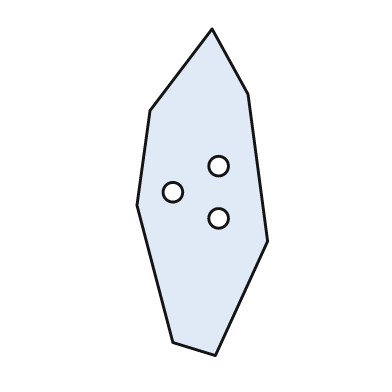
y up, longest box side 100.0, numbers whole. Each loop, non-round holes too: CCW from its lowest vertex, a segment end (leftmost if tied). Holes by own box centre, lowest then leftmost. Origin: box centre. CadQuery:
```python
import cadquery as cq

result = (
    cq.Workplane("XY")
    .moveTo(4.0, -50.0)
    .lineTo(20.0, -15.0)
    .lineTo(14.0, 30.0)
    .lineTo(3.0, 50.0)
    .lineTo(-16.0, 25.0)
    .lineTo(-20.0, -4.0)
    .lineTo(-9.0, -46.0)
    .close()
    .moveTo(5.0, -8.0)
    .circle(3.0)
    .moveTo(-9.0, 0.0)
    .circle(3.0)
    .moveTo(5.0, 8.0)
    .circle(3.0)
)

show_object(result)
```